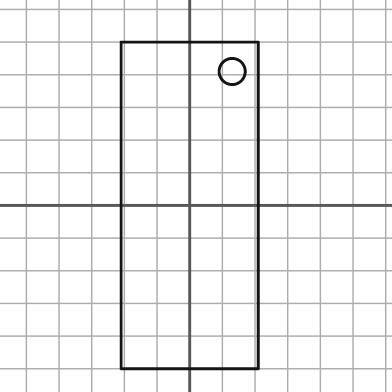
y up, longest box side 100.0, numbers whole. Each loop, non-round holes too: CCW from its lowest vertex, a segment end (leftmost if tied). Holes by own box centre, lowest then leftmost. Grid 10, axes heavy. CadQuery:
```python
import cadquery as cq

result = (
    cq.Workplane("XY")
    .moveTo(-21.0, -50.0)
    .lineTo(21.0, -50.0)
    .lineTo(21.0, 50.0)
    .lineTo(-21.0, 50.0)
    .close()
    .moveTo(13.0, 41.0)
    .circle(4.0)
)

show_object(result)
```